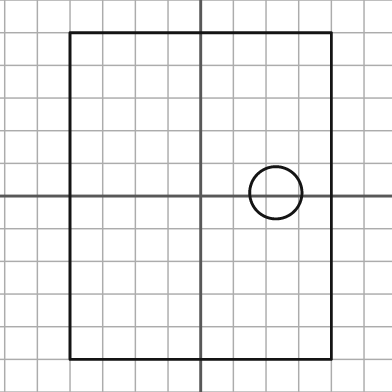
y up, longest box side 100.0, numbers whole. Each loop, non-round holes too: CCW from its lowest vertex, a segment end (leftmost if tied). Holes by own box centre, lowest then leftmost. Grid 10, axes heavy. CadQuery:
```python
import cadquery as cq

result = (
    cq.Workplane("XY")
    .moveTo(-40.0, -50.0)
    .lineTo(40.0, -50.0)
    .lineTo(40.0, 50.0)
    .lineTo(-40.0, 50.0)
    .close()
    .moveTo(23.0, 1.0)
    .circle(8.0)
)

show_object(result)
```